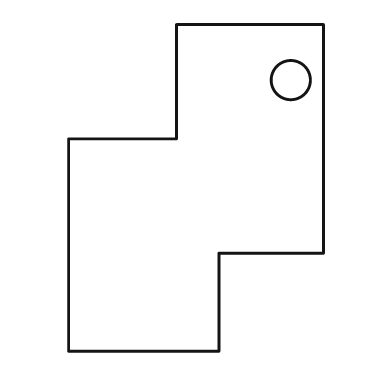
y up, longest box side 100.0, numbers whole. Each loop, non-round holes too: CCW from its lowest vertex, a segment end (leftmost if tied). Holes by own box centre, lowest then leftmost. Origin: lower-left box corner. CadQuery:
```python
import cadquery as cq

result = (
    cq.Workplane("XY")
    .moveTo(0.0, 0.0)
    .lineTo(46.0, 0.0)
    .lineTo(46.0, 30.0)
    .lineTo(78.0, 30.0)
    .lineTo(78.0, 100.0)
    .lineTo(33.0, 100.0)
    .lineTo(33.0, 65.0)
    .lineTo(0.0, 65.0)
    .close()
    .moveTo(68.0, 83.0)
    .circle(6.0)
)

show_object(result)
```